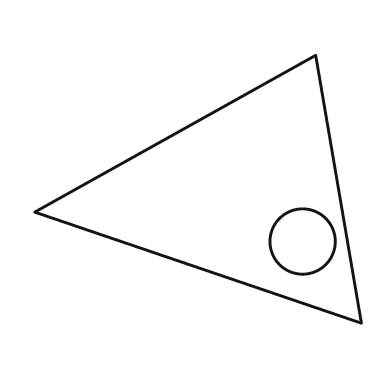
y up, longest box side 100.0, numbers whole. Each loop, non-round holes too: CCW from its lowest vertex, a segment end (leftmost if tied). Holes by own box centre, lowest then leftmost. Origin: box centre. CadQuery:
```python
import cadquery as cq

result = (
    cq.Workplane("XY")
    .moveTo(50.0, -41.0)
    .lineTo(36.0, 41.0)
    .lineTo(-50.0, -7.0)
    .close()
    .moveTo(32.0, -16.0)
    .circle(10.0)
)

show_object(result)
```